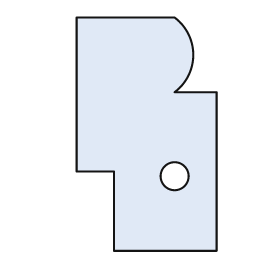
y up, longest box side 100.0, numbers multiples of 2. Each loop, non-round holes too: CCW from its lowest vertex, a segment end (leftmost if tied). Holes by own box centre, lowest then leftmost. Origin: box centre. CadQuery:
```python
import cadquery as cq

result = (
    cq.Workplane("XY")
    .moveTo(-14.0, -50.0)
    .lineTo(30.0, -50.0)
    .lineTo(30.0, 18.0)
    .lineTo(12.0, 18.0)
    .threePointArc((20.0, 34.0), (12.0, 50.0))
    .lineTo(-30.0, 50.0)
    .lineTo(-30.0, -16.0)
    .lineTo(-14.0, -16.0)
    .close()
    .moveTo(12.0, -18.0)
    .circle(6.0)
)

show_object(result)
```